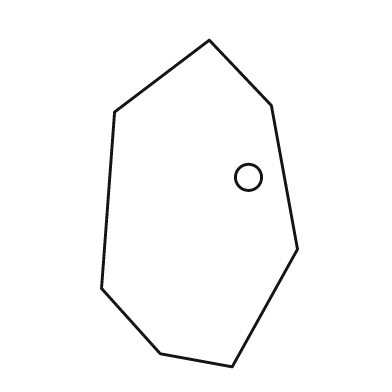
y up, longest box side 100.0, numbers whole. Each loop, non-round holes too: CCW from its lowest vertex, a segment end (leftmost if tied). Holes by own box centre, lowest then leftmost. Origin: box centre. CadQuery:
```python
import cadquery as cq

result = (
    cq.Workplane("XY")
    .moveTo(10.0, -50.0)
    .lineTo(30.0, -14.0)
    .lineTo(22.0, 30.0)
    .lineTo(3.0, 50.0)
    .lineTo(-26.0, 28.0)
    .lineTo(-30.0, -26.0)
    .lineTo(-12.0, -46.0)
    .close()
    .moveTo(15.0, 8.0)
    .circle(4.0)
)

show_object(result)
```